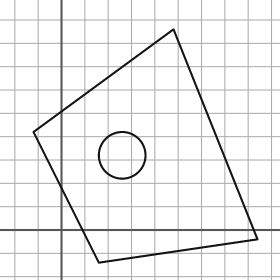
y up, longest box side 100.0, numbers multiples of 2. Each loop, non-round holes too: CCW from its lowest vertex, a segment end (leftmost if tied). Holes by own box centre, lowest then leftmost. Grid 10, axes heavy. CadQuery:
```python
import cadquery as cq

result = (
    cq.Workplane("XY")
    .moveTo(16.0, -14.0)
    .lineTo(84.0, -4.0)
    .lineTo(48.0, 86.0)
    .lineTo(-12.0, 42.0)
    .close()
    .moveTo(26.0, 32.0)
    .circle(10.0)
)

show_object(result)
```